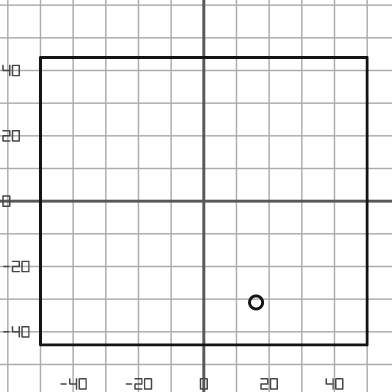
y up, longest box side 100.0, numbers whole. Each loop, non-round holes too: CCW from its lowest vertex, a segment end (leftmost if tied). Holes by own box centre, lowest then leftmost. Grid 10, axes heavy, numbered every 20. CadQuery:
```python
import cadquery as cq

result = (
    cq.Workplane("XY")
    .moveTo(-50.0, -44.0)
    .lineTo(50.0, -44.0)
    .lineTo(50.0, 44.0)
    .lineTo(-50.0, 44.0)
    .close()
    .moveTo(16.0, -31.0)
    .circle(2.0)
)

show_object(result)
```